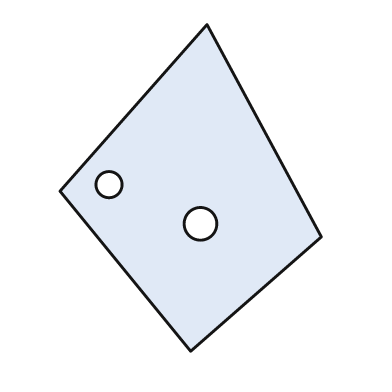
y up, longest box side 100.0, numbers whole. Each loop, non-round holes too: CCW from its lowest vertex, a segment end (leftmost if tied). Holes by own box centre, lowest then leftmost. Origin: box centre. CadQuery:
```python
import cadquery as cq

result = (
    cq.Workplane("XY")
    .moveTo(0.0, -50.0)
    .lineTo(40.0, -15.0)
    .lineTo(5.0, 50.0)
    .lineTo(-40.0, -1.0)
    .close()
    .moveTo(3.0, -11.0)
    .circle(5.0)
    .moveTo(-25.0, 1.0)
    .circle(4.0)
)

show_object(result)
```